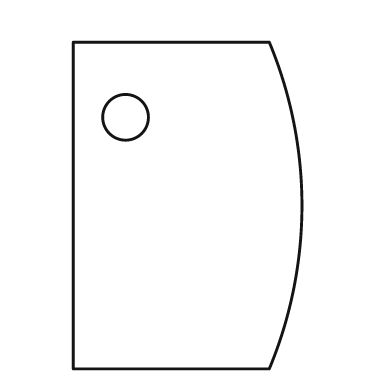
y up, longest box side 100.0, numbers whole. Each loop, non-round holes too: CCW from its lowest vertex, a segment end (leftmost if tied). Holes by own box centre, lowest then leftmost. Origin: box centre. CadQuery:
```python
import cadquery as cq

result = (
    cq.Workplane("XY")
    .moveTo(-35.0, -50.0)
    .lineTo(25.0, -50.0)
    .threePointArc((35.0, 0.0), (25.0, 50.0))
    .lineTo(-35.0, 50.0)
    .close()
    .moveTo(-19.0, 27.0)
    .circle(7.0)
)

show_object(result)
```